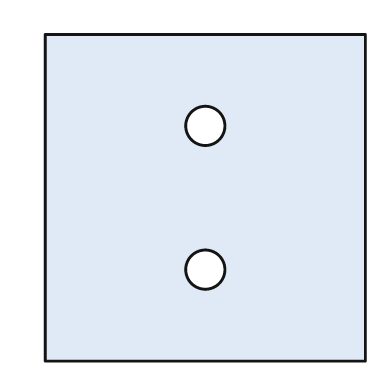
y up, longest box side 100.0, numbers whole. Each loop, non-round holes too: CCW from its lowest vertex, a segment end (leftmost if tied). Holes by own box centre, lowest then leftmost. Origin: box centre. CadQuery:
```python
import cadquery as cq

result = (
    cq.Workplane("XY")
    .moveTo(-49.0, -50.0)
    .lineTo(49.0, -50.0)
    .lineTo(49.0, 50.0)
    .lineTo(-49.0, 50.0)
    .close()
    .moveTo(0.0, -22.0)
    .circle(6.0)
    .moveTo(0.0, 22.0)
    .circle(6.0)
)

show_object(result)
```